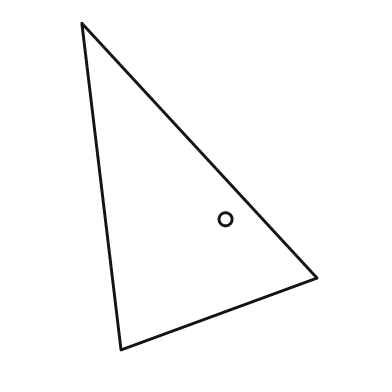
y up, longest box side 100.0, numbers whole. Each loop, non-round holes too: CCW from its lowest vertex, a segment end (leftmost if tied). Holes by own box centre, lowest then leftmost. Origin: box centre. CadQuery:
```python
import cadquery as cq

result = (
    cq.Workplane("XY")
    .moveTo(-24.0, -50.0)
    .lineTo(36.0, -28.0)
    .lineTo(-36.0, 50.0)
    .close()
    .moveTo(8.0, -10.0)
    .circle(2.0)
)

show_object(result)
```